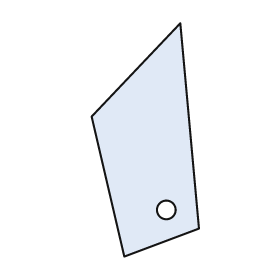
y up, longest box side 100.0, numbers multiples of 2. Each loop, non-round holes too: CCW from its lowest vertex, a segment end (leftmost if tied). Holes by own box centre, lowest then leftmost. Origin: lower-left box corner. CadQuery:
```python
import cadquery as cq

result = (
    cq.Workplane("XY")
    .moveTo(14.0, 0.0)
    .lineTo(46.0, 12.0)
    .lineTo(38.0, 100.0)
    .lineTo(0.0, 60.0)
    .close()
    .moveTo(32.0, 20.0)
    .circle(4.0)
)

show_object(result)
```